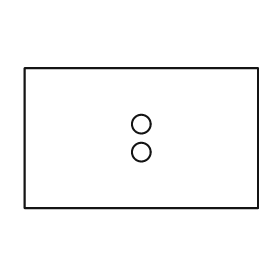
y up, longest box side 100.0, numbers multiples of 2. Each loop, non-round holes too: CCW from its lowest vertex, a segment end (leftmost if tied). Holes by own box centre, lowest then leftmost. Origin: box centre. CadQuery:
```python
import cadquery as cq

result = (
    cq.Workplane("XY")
    .moveTo(-50.0, -30.0)
    .lineTo(50.0, -30.0)
    .lineTo(50.0, 30.0)
    .lineTo(-50.0, 30.0)
    .close()
    .moveTo(0.0, -6.0)
    .circle(4.0)
    .moveTo(0.0, 6.0)
    .circle(4.0)
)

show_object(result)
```